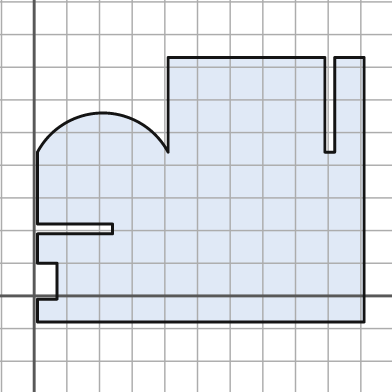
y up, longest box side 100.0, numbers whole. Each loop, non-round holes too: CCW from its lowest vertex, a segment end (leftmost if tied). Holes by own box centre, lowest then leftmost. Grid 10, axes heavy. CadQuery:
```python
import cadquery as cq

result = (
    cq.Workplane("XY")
    .moveTo(1.0, -8.0)
    .lineTo(101.0, -8.0)
    .lineTo(101.0, 73.0)
    .lineTo(92.0, 73.0)
    .lineTo(92.0, 44.0)
    .lineTo(89.0, 44.0)
    .lineTo(89.0, 73.0)
    .lineTo(41.0, 73.0)
    .lineTo(41.0, 44.0)
    .threePointArc((21.0, 56.0), (1.0, 44.0))
    .lineTo(1.0, 22.0)
    .lineTo(24.0, 22.0)
    .lineTo(24.0, 19.0)
    .lineTo(1.0, 19.0)
    .lineTo(1.0, 10.0)
    .lineTo(7.0, 10.0)
    .lineTo(7.0, -1.0)
    .lineTo(1.0, -1.0)
    .close()
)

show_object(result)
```